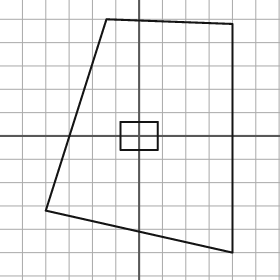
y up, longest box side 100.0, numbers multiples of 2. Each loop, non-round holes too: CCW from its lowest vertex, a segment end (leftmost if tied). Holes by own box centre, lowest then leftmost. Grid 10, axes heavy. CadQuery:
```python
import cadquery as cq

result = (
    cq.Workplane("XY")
    .moveTo(40.0, -50.0)
    .lineTo(40.0, 48.0)
    .lineTo(-14.0, 50.0)
    .lineTo(-40.0, -32.0)
    .close()
    .moveTo(-8.0, -6.0)
    .lineTo(8.0, -6.0)
    .lineTo(8.0, 6.0)
    .lineTo(-8.0, 6.0)
    .close()
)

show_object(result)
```